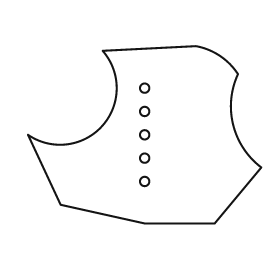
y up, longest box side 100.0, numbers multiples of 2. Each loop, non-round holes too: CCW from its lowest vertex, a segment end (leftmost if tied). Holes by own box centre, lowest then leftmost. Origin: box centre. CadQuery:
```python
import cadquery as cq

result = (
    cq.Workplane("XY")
    .moveTo(0.0, -38.0)
    .lineTo(30.0, -38.0)
    .lineTo(50.0, -14.0)
    .threePointArc((38.0, 4.0), (40.0, 26.0))
    .threePointArc((32.0, 34.0), (22.0, 38.0))
    .lineTo(-18.0, 36.0)
    .threePointArc((-18.0, 4.0), (-50.0, 0.0))
    .lineTo(-36.0, -30.0)
    .close()
    .moveTo(0.0, -20.0)
    .circle(2.0)
    .moveTo(0.0, -10.0)
    .circle(2.0)
    .moveTo(0.0, 0.0)
    .circle(2.0)
    .moveTo(0.0, 10.0)
    .circle(2.0)
    .moveTo(0.0, 20.0)
    .circle(2.0)
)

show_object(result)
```